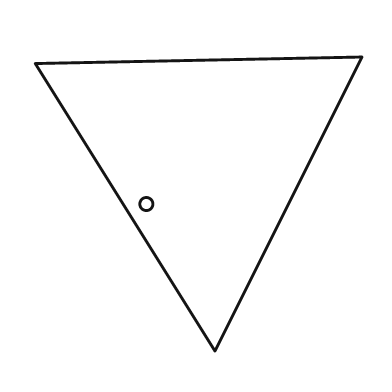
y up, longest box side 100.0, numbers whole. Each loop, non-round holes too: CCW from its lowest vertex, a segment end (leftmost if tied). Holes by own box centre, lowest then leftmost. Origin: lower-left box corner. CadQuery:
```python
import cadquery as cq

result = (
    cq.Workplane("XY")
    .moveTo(55.0, 0.0)
    .lineTo(100.0, 90.0)
    .lineTo(0.0, 88.0)
    .close()
    .moveTo(34.0, 45.0)
    .circle(2.0)
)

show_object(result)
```